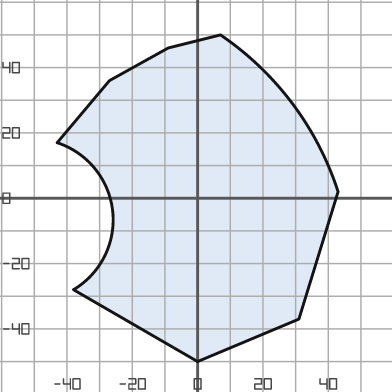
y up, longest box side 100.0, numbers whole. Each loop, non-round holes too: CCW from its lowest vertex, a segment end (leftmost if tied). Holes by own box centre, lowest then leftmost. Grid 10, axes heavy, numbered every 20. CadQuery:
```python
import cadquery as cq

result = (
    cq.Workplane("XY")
    .moveTo(0.0, -50.0)
    .lineTo(31.0, -37.0)
    .lineTo(43.0, 2.0)
    .threePointArc((29.0, 29.0), (7.0, 50.0))
    .lineTo(-9.0, 46.0)
    .lineTo(-27.0, 36.0)
    .lineTo(-43.0, 17.0)
    .threePointArc((-26.0, -4.0), (-38.0, -28.0))
    .close()
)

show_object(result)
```